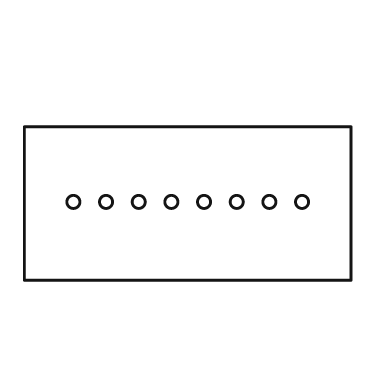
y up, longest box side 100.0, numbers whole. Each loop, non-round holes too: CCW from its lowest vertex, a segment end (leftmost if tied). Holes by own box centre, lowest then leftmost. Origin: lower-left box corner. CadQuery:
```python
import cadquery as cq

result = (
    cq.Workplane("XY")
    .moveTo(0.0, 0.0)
    .lineTo(100.0, 0.0)
    .lineTo(100.0, 47.0)
    .lineTo(0.0, 47.0)
    .close()
    .moveTo(15.0, 24.0)
    .circle(2.0)
    .moveTo(25.0, 24.0)
    .circle(2.0)
    .moveTo(35.0, 24.0)
    .circle(2.0)
    .moveTo(45.0, 24.0)
    .circle(2.0)
    .moveTo(55.0, 24.0)
    .circle(2.0)
    .moveTo(65.0, 24.0)
    .circle(2.0)
    .moveTo(75.0, 24.0)
    .circle(2.0)
    .moveTo(85.0, 24.0)
    .circle(2.0)
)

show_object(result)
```